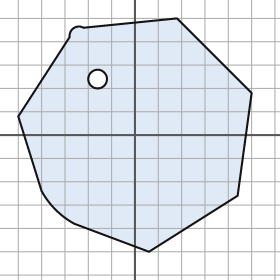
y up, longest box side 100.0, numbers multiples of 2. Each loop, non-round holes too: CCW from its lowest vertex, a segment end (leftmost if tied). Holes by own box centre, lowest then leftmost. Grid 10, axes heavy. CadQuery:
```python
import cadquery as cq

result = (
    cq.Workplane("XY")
    .moveTo(6.0, -50.0)
    .lineTo(44.0, -26.0)
    .lineTo(50.0, 18.0)
    .lineTo(18.0, 50.0)
    .lineTo(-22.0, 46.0)
    .threePointArc((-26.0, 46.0), (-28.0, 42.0))
    .lineTo(-50.0, 8.0)
    .lineTo(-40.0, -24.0)
    .threePointArc((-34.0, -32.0), (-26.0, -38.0))
    .close()
    .moveTo(-16.0, 24.0)
    .circle(4.0)
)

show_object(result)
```